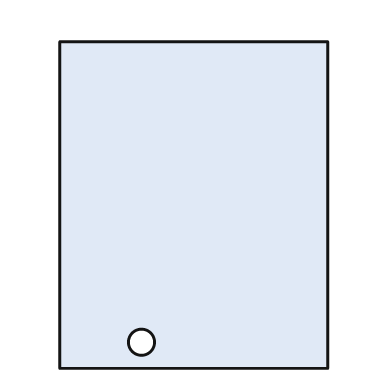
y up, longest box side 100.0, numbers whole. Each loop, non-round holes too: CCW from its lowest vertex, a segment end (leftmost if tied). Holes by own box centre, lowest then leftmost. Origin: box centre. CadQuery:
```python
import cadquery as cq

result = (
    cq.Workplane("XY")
    .moveTo(-41.0, -50.0)
    .lineTo(41.0, -50.0)
    .lineTo(41.0, 50.0)
    .lineTo(-41.0, 50.0)
    .close()
    .moveTo(-16.0, -42.0)
    .circle(4.0)
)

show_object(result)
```